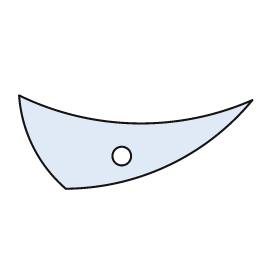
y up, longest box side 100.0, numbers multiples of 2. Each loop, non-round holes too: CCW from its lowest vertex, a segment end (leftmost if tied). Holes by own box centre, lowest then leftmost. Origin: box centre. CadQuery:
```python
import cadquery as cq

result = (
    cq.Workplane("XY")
    .moveTo(-30.0, -20.0)
    .threePointArc((14.0, -10.0), (50.0, 18.0))
    .threePointArc((0.0, 8.0), (-50.0, 20.0))
    .threePointArc((-44.0, -2.0), (-30.0, -20.0))
    .close()
    .moveTo(-6.0, -6.0)
    .circle(4.0)
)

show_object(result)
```